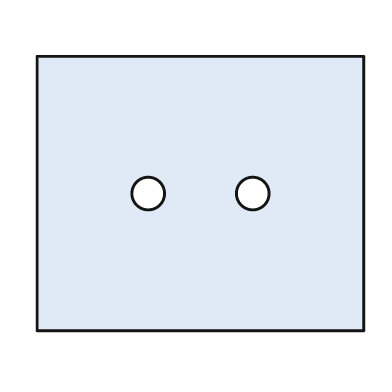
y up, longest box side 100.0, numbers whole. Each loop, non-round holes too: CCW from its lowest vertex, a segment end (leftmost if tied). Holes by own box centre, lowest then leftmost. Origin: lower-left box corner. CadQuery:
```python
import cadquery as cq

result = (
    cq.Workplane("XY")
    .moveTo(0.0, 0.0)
    .lineTo(100.0, 0.0)
    .lineTo(100.0, 84.0)
    .lineTo(0.0, 84.0)
    .close()
    .moveTo(34.0, 42.0)
    .circle(5.0)
    .moveTo(66.0, 42.0)
    .circle(5.0)
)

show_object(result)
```